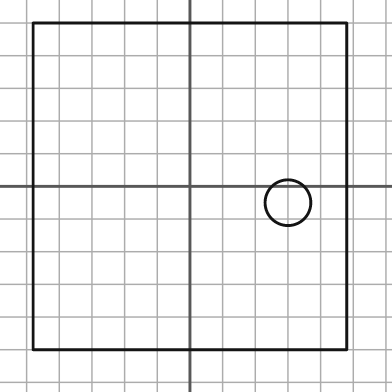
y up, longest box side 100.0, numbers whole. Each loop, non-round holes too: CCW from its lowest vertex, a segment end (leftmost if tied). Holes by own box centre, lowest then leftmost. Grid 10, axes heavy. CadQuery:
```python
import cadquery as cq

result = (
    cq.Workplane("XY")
    .moveTo(-48.0, -50.0)
    .lineTo(48.0, -50.0)
    .lineTo(48.0, 50.0)
    .lineTo(-48.0, 50.0)
    .close()
    .moveTo(30.0, -5.0)
    .circle(7.0)
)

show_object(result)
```